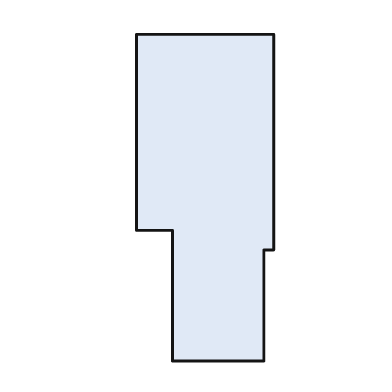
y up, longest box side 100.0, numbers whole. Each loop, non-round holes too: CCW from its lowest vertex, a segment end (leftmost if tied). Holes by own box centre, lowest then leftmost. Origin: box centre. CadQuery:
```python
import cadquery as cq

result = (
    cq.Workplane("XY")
    .moveTo(-10.0, -50.0)
    .lineTo(18.0, -50.0)
    .lineTo(18.0, -16.0)
    .lineTo(21.0, -16.0)
    .lineTo(21.0, 50.0)
    .lineTo(-21.0, 50.0)
    .lineTo(-21.0, -10.0)
    .lineTo(-10.0, -10.0)
    .close()
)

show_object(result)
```